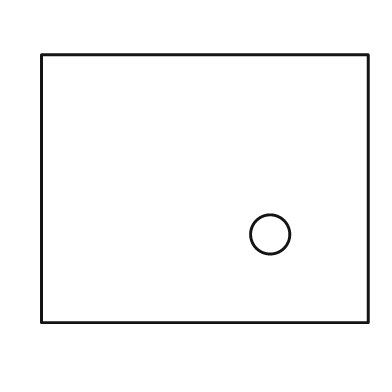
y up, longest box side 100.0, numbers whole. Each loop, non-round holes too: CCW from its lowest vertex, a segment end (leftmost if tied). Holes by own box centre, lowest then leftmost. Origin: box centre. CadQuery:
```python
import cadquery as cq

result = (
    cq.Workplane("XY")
    .moveTo(-50.0, -41.0)
    .lineTo(50.0, -41.0)
    .lineTo(50.0, 41.0)
    .lineTo(-50.0, 41.0)
    .close()
    .moveTo(20.0, -14.0)
    .circle(6.0)
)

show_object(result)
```